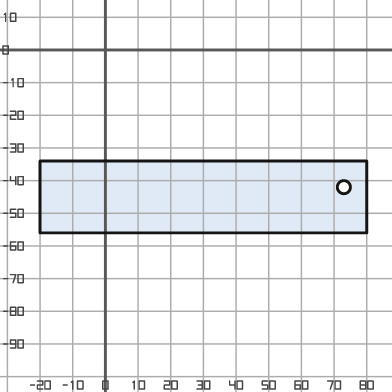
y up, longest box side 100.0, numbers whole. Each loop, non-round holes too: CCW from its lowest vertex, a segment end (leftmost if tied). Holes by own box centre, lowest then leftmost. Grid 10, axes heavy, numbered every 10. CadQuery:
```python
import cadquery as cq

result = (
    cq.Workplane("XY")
    .moveTo(-20.0, -56.0)
    .lineTo(80.0, -56.0)
    .lineTo(80.0, -34.0)
    .lineTo(-20.0, -34.0)
    .close()
    .moveTo(73.0, -42.0)
    .circle(2.0)
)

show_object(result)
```